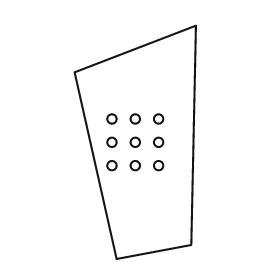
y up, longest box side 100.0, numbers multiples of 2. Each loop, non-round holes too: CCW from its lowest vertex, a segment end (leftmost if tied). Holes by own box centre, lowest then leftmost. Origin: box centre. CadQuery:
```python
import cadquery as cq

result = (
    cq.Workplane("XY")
    .moveTo(-8.0, -50.0)
    .lineTo(24.0, -44.0)
    .lineTo(26.0, 50.0)
    .lineTo(-26.0, 30.0)
    .close()
    .moveTo(-10.0, -10.0)
    .circle(2.0)
    .moveTo(0.0, -10.0)
    .circle(2.0)
    .moveTo(10.0, -10.0)
    .circle(2.0)
    .moveTo(-10.0, 0.0)
    .circle(2.0)
    .moveTo(0.0, 0.0)
    .circle(2.0)
    .moveTo(10.0, 0.0)
    .circle(2.0)
    .moveTo(-10.0, 10.0)
    .circle(2.0)
    .moveTo(0.0, 10.0)
    .circle(2.0)
    .moveTo(10.0, 10.0)
    .circle(2.0)
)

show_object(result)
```